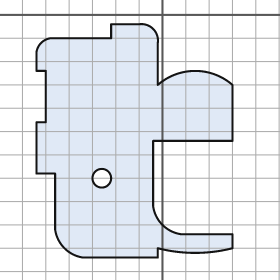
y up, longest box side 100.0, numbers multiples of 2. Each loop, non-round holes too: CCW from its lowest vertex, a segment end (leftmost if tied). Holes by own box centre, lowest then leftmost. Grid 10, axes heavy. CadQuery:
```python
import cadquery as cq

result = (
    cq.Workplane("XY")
    .moveTo(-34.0, -104.0)
    .lineTo(-2.0, -104.0)
    .lineTo(-2.0, -100.0)
    .threePointArc((14.0, -102.0), (30.0, -100.0))
    .lineTo(30.0, -94.0)
    .lineTo(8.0, -94.0)
    .threePointArc((0.0, -90.0), (-4.0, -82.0))
    .lineTo(-4.0, -54.0)
    .lineTo(30.0, -54.0)
    .lineTo(30.0, -30.0)
    .threePointArc((14.0, -24.0), (-2.0, -30.0))
    .lineTo(-2.0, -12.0)
    .threePointArc((-4.0, -6.0), (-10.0, -4.0))
    .lineTo(-22.0, -4.0)
    .lineTo(-22.0, -10.0)
    .lineTo(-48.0, -10.0)
    .threePointArc((-52.0, -12.0), (-54.0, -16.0))
    .lineTo(-54.0, -24.0)
    .lineTo(-50.0, -24.0)
    .lineTo(-50.0, -46.0)
    .lineTo(-54.0, -46.0)
    .lineTo(-54.0, -68.0)
    .lineTo(-46.0, -68.0)
    .lineTo(-46.0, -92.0)
    .threePointArc((-42.0, -100.0), (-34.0, -104.0))
    .close()
    .moveTo(-26.0, -70.0)
    .circle(4.0)
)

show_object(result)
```